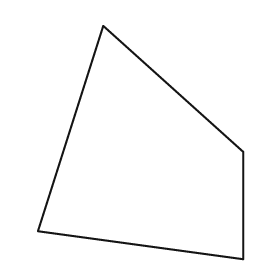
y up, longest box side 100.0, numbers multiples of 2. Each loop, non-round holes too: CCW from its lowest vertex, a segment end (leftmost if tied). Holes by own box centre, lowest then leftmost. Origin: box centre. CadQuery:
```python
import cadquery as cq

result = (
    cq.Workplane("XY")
    .moveTo(44.0, -50.0)
    .lineTo(44.0, -4.0)
    .lineTo(-16.0, 50.0)
    .lineTo(-44.0, -38.0)
    .close()
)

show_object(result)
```